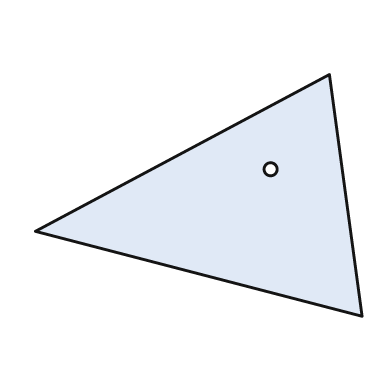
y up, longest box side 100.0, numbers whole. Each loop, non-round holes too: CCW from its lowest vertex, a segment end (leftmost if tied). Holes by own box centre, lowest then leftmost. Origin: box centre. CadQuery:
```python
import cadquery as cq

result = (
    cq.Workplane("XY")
    .moveTo(50.0, -37.0)
    .lineTo(40.0, 37.0)
    .lineTo(-50.0, -11.0)
    .close()
    .moveTo(22.0, 8.0)
    .circle(2.0)
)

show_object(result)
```